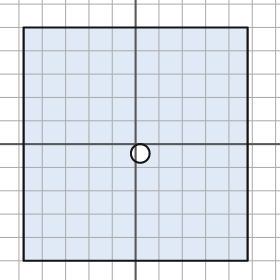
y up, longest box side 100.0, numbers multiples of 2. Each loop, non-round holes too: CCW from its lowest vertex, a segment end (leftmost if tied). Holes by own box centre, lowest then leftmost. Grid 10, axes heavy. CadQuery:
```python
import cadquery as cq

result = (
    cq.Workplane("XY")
    .moveTo(-48.0, -50.0)
    .lineTo(48.0, -50.0)
    .lineTo(48.0, 50.0)
    .lineTo(-48.0, 50.0)
    .close()
    .moveTo(2.0, -4.0)
    .circle(4.0)
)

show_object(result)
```